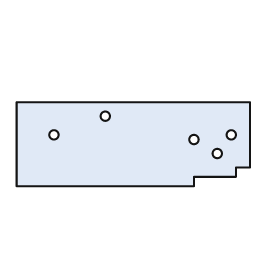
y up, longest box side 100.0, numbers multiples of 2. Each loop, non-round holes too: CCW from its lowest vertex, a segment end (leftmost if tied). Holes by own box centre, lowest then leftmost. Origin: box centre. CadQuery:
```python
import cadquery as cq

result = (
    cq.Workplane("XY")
    .moveTo(-50.0, -18.0)
    .lineTo(26.0, -18.0)
    .lineTo(26.0, -14.0)
    .lineTo(44.0, -14.0)
    .lineTo(44.0, -10.0)
    .lineTo(50.0, -10.0)
    .lineTo(50.0, 18.0)
    .lineTo(-50.0, 18.0)
    .close()
    .moveTo(36.0, -4.0)
    .circle(2.0)
    .moveTo(26.0, 2.0)
    .circle(2.0)
    .moveTo(-34.0, 4.0)
    .circle(2.0)
    .moveTo(42.0, 4.0)
    .circle(2.0)
    .moveTo(-12.0, 12.0)
    .circle(2.0)
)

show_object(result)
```